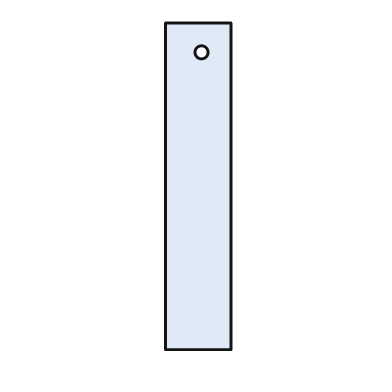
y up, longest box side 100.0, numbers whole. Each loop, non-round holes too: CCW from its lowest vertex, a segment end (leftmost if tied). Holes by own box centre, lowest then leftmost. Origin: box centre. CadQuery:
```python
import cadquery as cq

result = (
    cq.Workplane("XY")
    .moveTo(-10.0, -50.0)
    .lineTo(10.0, -50.0)
    .lineTo(10.0, 50.0)
    .lineTo(-10.0, 50.0)
    .close()
    .moveTo(1.0, 41.0)
    .circle(2.0)
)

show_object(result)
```